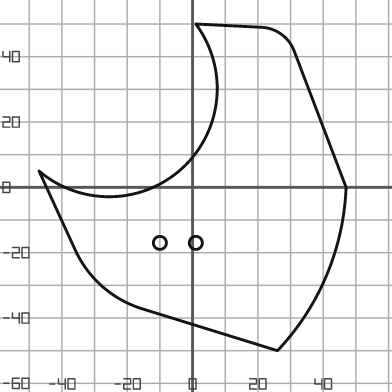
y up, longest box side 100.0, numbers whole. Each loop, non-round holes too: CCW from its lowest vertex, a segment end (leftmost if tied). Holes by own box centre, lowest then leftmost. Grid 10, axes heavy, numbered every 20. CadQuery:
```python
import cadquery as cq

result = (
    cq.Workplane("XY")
    .moveTo(26.0, -50.0)
    .threePointArc((41.0, -27.0), (47.0, 0.0))
    .lineTo(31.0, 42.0)
    .threePointArc((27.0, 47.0), (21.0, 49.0))
    .lineTo(1.0, 50.0)
    .threePointArc((-3.0, 6.0), (-47.0, 5.0))
    .lineTo(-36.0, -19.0)
    .threePointArc((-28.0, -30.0), (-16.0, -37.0))
    .close()
    .moveTo(-10.0, -17.0)
    .circle(2.0)
    .moveTo(1.0, -17.0)
    .circle(2.0)
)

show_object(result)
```